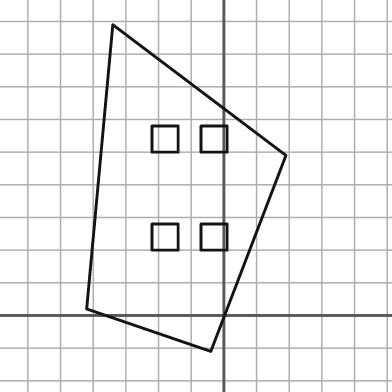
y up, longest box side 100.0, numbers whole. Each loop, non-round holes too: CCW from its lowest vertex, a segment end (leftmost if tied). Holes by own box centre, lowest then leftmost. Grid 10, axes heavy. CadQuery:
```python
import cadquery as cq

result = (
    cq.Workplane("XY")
    .moveTo(-4.0, -11.0)
    .lineTo(19.0, 49.0)
    .lineTo(-34.0, 89.0)
    .lineTo(-42.0, 2.0)
    .close()
    .moveTo(-22.0, 20.0)
    .lineTo(-14.0, 20.0)
    .lineTo(-14.0, 28.0)
    .lineTo(-22.0, 28.0)
    .close()
    .moveTo(-7.0, 20.0)
    .lineTo(1.0, 20.0)
    .lineTo(1.0, 28.0)
    .lineTo(-7.0, 28.0)
    .close()
    .moveTo(-22.0, 50.0)
    .lineTo(-14.0, 50.0)
    .lineTo(-14.0, 58.0)
    .lineTo(-22.0, 58.0)
    .close()
    .moveTo(-7.0, 50.0)
    .lineTo(1.0, 50.0)
    .lineTo(1.0, 58.0)
    .lineTo(-7.0, 58.0)
    .close()
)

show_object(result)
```